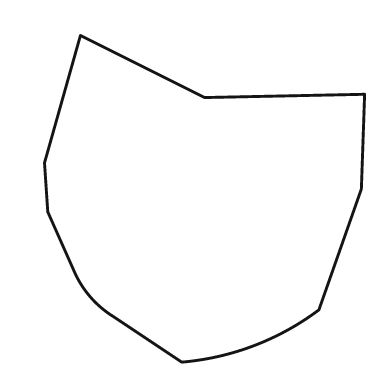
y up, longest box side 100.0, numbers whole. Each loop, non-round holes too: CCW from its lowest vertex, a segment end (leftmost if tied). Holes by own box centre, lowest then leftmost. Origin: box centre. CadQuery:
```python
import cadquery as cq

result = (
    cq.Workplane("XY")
    .moveTo(-7.0, -50.0)
    .threePointArc((15.0, -45.0), (35.0, -34.0))
    .lineTo(48.0, 3.0)
    .lineTo(49.0, 32.0)
    .lineTo(0.0, 31.0)
    .lineTo(-38.0, 50.0)
    .lineTo(-49.0, 11.0)
    .lineTo(-48.0, -4.0)
    .lineTo(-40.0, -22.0)
    .threePointArc((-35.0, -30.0), (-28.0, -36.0))
    .close()
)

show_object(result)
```